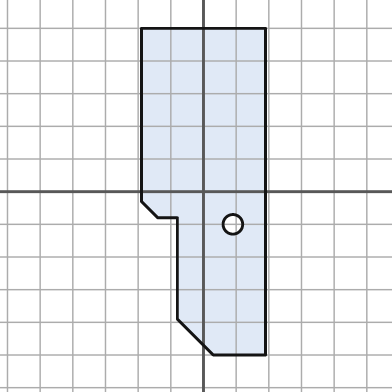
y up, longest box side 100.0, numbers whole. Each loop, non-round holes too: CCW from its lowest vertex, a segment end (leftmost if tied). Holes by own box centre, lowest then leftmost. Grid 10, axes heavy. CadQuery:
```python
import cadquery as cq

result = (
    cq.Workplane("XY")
    .moveTo(3.0, -50.0)
    .lineTo(19.0, -50.0)
    .lineTo(19.0, 50.0)
    .lineTo(-19.0, 50.0)
    .lineTo(-19.0, -3.0)
    .lineTo(-14.0, -8.0)
    .lineTo(-8.0, -8.0)
    .lineTo(-8.0, -39.0)
    .close()
    .moveTo(9.0, -10.0)
    .circle(3.0)
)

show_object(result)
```